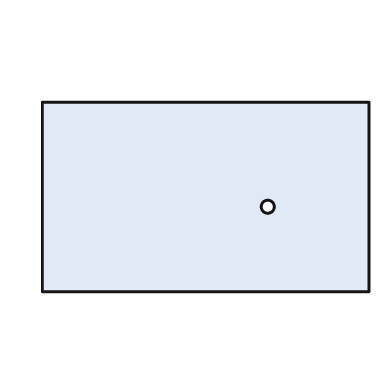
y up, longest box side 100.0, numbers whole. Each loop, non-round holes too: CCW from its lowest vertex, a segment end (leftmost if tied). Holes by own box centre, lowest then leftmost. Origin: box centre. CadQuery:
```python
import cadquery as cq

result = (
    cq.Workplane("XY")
    .moveTo(-50.0, -29.0)
    .lineTo(50.0, -29.0)
    .lineTo(50.0, 29.0)
    .lineTo(-50.0, 29.0)
    .close()
    .moveTo(19.0, -3.0)
    .circle(2.0)
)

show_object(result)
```